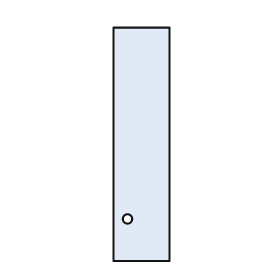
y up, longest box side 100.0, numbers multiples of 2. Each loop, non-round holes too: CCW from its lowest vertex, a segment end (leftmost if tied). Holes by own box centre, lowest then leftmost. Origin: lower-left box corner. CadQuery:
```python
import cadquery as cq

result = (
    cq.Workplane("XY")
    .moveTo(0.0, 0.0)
    .lineTo(24.0, 0.0)
    .lineTo(24.0, 100.0)
    .lineTo(0.0, 100.0)
    .close()
    .moveTo(6.0, 18.0)
    .circle(2.0)
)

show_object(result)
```